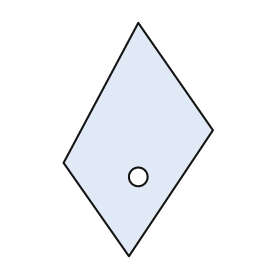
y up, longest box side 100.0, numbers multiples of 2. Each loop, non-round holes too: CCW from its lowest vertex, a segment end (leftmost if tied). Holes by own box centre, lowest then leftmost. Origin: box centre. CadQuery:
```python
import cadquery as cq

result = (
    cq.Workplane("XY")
    .moveTo(-4.0, -50.0)
    .lineTo(32.0, 4.0)
    .lineTo(0.0, 50.0)
    .lineTo(-32.0, -10.0)
    .close()
    .moveTo(0.0, -16.0)
    .circle(4.0)
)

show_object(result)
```